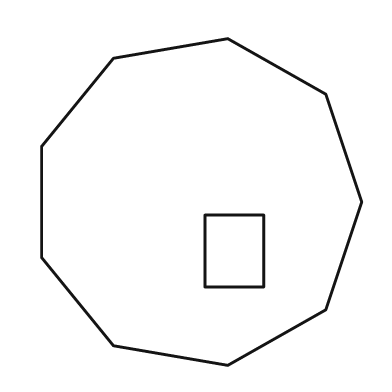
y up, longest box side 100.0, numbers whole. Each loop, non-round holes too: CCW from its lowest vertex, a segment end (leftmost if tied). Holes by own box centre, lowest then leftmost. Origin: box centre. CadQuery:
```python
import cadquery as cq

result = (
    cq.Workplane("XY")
    .moveTo(8.0, -50.0)
    .lineTo(38.0, -33.0)
    .lineTo(49.0, 0.0)
    .lineTo(38.0, 33.0)
    .lineTo(8.0, 50.0)
    .lineTo(-27.0, 44.0)
    .lineTo(-49.0, 17.0)
    .lineTo(-49.0, -17.0)
    .lineTo(-27.0, -44.0)
    .close()
    .moveTo(1.0, -26.0)
    .lineTo(19.0, -26.0)
    .lineTo(19.0, -4.0)
    .lineTo(1.0, -4.0)
    .close()
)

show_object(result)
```